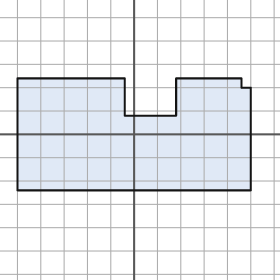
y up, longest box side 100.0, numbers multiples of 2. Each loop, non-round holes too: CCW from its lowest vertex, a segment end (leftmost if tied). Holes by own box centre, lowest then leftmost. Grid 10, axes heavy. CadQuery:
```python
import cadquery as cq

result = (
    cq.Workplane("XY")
    .moveTo(-50.0, -24.0)
    .lineTo(50.0, -24.0)
    .lineTo(50.0, 20.0)
    .lineTo(46.0, 20.0)
    .lineTo(46.0, 24.0)
    .lineTo(18.0, 24.0)
    .lineTo(18.0, 8.0)
    .lineTo(-4.0, 8.0)
    .lineTo(-4.0, 24.0)
    .lineTo(-50.0, 24.0)
    .close()
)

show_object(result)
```